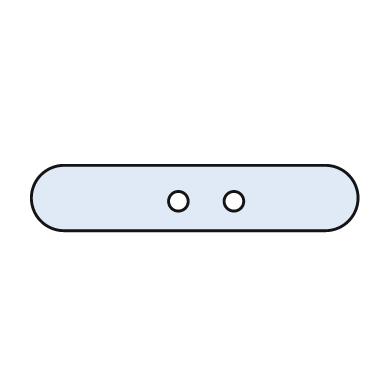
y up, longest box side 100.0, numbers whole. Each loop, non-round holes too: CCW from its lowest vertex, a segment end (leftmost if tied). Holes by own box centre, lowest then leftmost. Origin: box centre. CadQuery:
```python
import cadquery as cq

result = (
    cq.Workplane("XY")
    .moveTo(-40.0, -10.0)
    .lineTo(40.0, -10.0)
    .threePointArc((50.0, 0.0), (40.0, 10.0))
    .lineTo(-40.0, 10.0)
    .threePointArc((-50.0, 0.0), (-40.0, -10.0))
    .close()
    .moveTo(-5.0, -1.0)
    .circle(3.0)
    .moveTo(12.0, -1.0)
    .circle(3.0)
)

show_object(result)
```